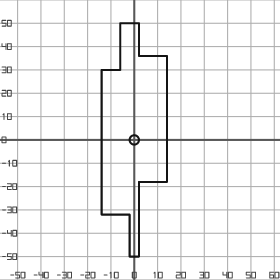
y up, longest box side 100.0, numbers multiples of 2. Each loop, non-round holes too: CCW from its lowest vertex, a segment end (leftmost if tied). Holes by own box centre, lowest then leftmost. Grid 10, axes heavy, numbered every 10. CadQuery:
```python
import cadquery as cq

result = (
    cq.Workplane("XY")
    .moveTo(-2.0, -50.0)
    .lineTo(2.0, -50.0)
    .lineTo(2.0, -18.0)
    .lineTo(14.0, -18.0)
    .lineTo(14.0, 36.0)
    .lineTo(2.0, 36.0)
    .lineTo(2.0, 50.0)
    .lineTo(-6.0, 50.0)
    .lineTo(-6.0, 30.0)
    .lineTo(-14.0, 30.0)
    .lineTo(-14.0, -32.0)
    .lineTo(-2.0, -32.0)
    .close()
    .moveTo(0.0, 0.0)
    .circle(2.0)
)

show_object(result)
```